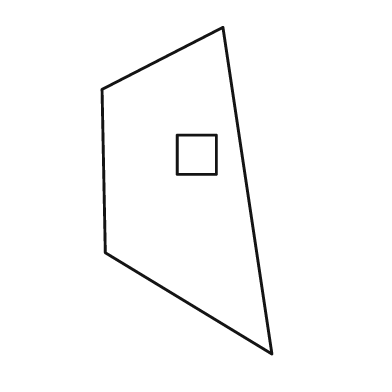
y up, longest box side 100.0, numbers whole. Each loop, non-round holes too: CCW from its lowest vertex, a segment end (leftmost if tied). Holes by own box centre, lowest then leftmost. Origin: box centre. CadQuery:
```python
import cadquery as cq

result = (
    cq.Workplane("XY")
    .moveTo(26.0, -50.0)
    .lineTo(11.0, 50.0)
    .lineTo(-26.0, 31.0)
    .lineTo(-25.0, -19.0)
    .close()
    .moveTo(-3.0, 5.0)
    .lineTo(9.0, 5.0)
    .lineTo(9.0, 17.0)
    .lineTo(-3.0, 17.0)
    .close()
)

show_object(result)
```